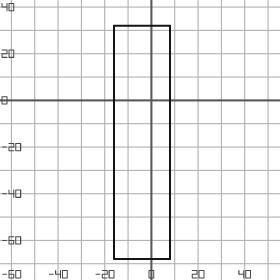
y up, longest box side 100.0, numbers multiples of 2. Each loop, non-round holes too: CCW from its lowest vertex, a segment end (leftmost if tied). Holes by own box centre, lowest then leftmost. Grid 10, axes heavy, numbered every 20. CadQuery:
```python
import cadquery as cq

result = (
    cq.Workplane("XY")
    .moveTo(-16.0, -68.0)
    .lineTo(8.0, -68.0)
    .lineTo(8.0, 32.0)
    .lineTo(-16.0, 32.0)
    .close()
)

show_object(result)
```